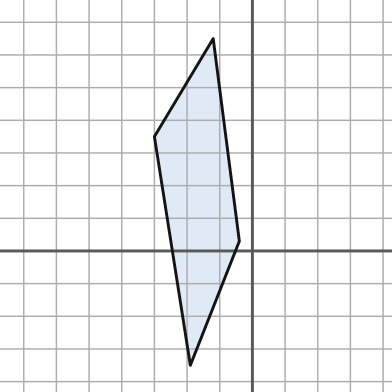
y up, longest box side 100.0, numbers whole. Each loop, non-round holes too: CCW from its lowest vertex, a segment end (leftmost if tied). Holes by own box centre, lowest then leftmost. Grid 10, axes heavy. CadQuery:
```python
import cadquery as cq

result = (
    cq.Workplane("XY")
    .moveTo(-19.0, -35.0)
    .lineTo(-4.0, 3.0)
    .lineTo(-12.0, 65.0)
    .lineTo(-30.0, 35.0)
    .close()
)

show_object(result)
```